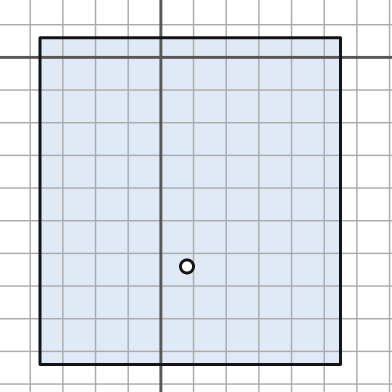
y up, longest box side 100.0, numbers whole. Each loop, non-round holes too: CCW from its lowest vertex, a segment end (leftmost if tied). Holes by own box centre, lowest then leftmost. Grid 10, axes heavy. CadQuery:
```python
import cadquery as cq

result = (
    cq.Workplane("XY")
    .moveTo(-37.0, -94.0)
    .lineTo(55.0, -94.0)
    .lineTo(55.0, 6.0)
    .lineTo(-37.0, 6.0)
    .close()
    .moveTo(8.0, -64.0)
    .circle(2.0)
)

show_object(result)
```